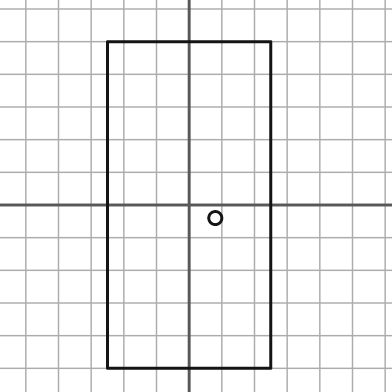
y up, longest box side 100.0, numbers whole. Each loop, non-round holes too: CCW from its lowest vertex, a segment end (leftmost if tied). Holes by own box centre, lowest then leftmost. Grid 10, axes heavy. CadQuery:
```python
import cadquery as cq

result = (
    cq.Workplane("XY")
    .moveTo(-25.0, -50.0)
    .lineTo(25.0, -50.0)
    .lineTo(25.0, 50.0)
    .lineTo(-25.0, 50.0)
    .close()
    .moveTo(8.0, -4.0)
    .circle(2.0)
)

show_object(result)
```